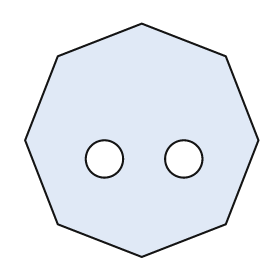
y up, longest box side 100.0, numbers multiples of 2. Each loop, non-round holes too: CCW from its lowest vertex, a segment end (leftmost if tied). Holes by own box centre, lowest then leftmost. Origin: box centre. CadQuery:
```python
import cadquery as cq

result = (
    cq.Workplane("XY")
    .moveTo(0.0, -50.0)
    .lineTo(36.0, -36.0)
    .lineTo(50.0, 0.0)
    .lineTo(36.0, 36.0)
    .lineTo(0.0, 50.0)
    .lineTo(-36.0, 36.0)
    .lineTo(-50.0, 0.0)
    .lineTo(-36.0, -36.0)
    .close()
    .moveTo(-16.0, -8.0)
    .circle(8.0)
    .moveTo(18.0, -8.0)
    .circle(8.0)
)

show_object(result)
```